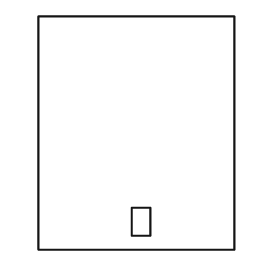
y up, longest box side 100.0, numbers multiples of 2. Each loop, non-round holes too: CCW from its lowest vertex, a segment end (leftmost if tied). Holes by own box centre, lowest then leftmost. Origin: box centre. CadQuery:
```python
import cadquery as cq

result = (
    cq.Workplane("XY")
    .moveTo(-42.0, -50.0)
    .lineTo(42.0, -50.0)
    .lineTo(42.0, 50.0)
    .lineTo(-42.0, 50.0)
    .close()
    .moveTo(-2.0, -44.0)
    .lineTo(6.0, -44.0)
    .lineTo(6.0, -32.0)
    .lineTo(-2.0, -32.0)
    .close()
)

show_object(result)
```